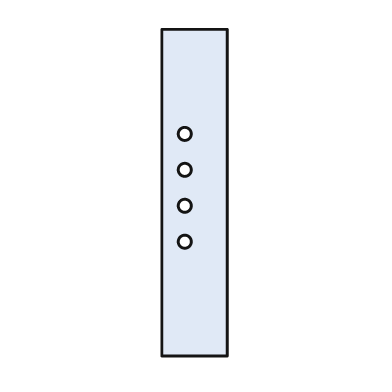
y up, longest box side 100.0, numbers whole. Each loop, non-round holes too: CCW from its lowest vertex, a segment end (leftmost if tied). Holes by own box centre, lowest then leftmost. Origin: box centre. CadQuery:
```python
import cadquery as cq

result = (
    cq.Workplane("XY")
    .moveTo(-10.0, -50.0)
    .lineTo(10.0, -50.0)
    .lineTo(10.0, 50.0)
    .lineTo(-10.0, 50.0)
    .close()
    .moveTo(-3.0, -15.0)
    .circle(2.0)
    .moveTo(-3.0, -4.0)
    .circle(2.0)
    .moveTo(-3.0, 7.0)
    .circle(2.0)
    .moveTo(-3.0, 18.0)
    .circle(2.0)
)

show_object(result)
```